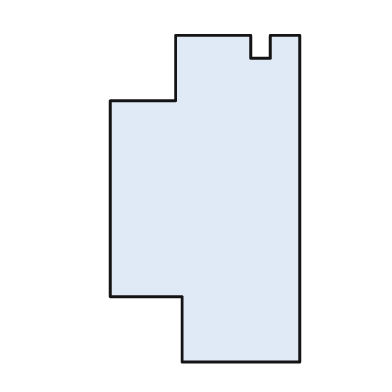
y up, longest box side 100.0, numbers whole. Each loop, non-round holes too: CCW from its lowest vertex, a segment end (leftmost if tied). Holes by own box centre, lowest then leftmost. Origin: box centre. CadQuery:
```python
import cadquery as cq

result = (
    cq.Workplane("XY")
    .moveTo(-7.0, -50.0)
    .lineTo(29.0, -50.0)
    .lineTo(29.0, 50.0)
    .lineTo(20.0, 50.0)
    .lineTo(20.0, 43.0)
    .lineTo(14.0, 43.0)
    .lineTo(14.0, 50.0)
    .lineTo(-9.0, 50.0)
    .lineTo(-9.0, 30.0)
    .lineTo(-29.0, 30.0)
    .lineTo(-29.0, -30.0)
    .lineTo(-7.0, -30.0)
    .close()
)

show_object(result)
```